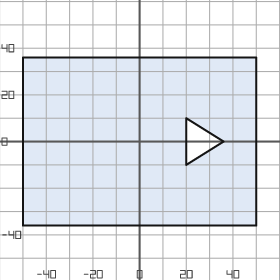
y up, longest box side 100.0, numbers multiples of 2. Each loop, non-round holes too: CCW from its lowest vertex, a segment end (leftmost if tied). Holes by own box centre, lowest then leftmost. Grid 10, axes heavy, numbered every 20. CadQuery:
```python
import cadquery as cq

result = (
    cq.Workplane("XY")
    .moveTo(-50.0, -36.0)
    .lineTo(50.0, -36.0)
    .lineTo(50.0, 36.0)
    .lineTo(-50.0, 36.0)
    .close()
    .moveTo(20.0, -10.0)
    .lineTo(36.0, 0.0)
    .lineTo(20.0, 10.0)
    .close()
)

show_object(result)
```